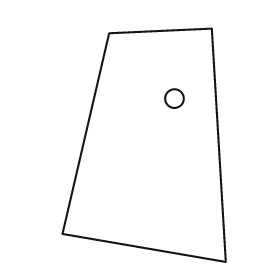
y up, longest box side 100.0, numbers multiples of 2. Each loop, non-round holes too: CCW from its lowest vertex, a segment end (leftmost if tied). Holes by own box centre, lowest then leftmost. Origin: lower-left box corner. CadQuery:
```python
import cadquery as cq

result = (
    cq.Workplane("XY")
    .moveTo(70.0, 0.0)
    .lineTo(64.0, 100.0)
    .lineTo(20.0, 98.0)
    .lineTo(0.0, 12.0)
    .close()
    .moveTo(48.0, 70.0)
    .circle(4.0)
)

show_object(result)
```